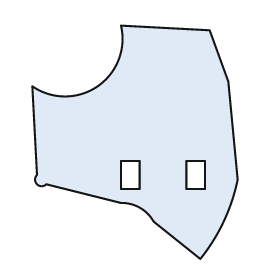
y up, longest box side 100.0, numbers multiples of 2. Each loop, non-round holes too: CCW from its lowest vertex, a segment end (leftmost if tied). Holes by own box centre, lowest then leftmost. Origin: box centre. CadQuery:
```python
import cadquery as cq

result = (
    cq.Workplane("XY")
    .moveTo(28.0, -50.0)
    .threePointArc((38.0, -34.0), (44.0, -16.0))
    .lineTo(40.0, 26.0)
    .lineTo(32.0, 48.0)
    .lineTo(-6.0, 50.0)
    .threePointArc((-16.0, 24.0), (-44.0, 24.0))
    .lineTo(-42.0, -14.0)
    .threePointArc((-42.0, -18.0), (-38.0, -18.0))
    .lineTo(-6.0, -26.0)
    .threePointArc((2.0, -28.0), (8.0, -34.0))
    .close()
    .moveTo(-6.0, -20.0)
    .lineTo(2.0, -20.0)
    .lineTo(2.0, -8.0)
    .lineTo(-6.0, -8.0)
    .close()
    .moveTo(22.0, -20.0)
    .lineTo(30.0, -20.0)
    .lineTo(30.0, -8.0)
    .lineTo(22.0, -8.0)
    .close()
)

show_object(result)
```